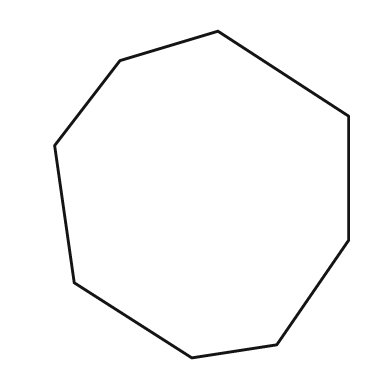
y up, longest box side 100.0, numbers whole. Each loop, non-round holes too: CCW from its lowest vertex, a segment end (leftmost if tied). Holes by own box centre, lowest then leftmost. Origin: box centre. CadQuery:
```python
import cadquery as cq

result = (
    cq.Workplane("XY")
    .moveTo(-3.0, -50.0)
    .lineTo(23.0, -46.0)
    .lineTo(45.0, -14.0)
    .lineTo(45.0, 24.0)
    .lineTo(5.0, 50.0)
    .lineTo(-25.0, 41.0)
    .lineTo(-45.0, 15.0)
    .lineTo(-39.0, -27.0)
    .close()
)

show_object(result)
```